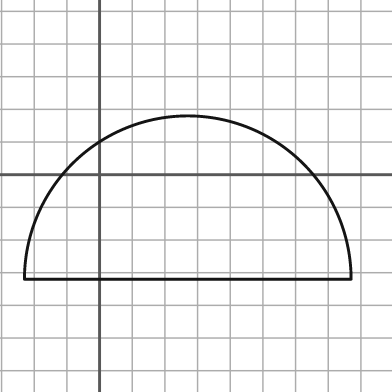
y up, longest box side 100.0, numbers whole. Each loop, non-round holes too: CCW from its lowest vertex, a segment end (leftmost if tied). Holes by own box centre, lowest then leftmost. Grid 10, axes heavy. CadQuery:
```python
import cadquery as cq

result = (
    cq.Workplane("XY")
    .moveTo(-23.0, -32.0)
    .lineTo(77.0, -32.0)
    .threePointArc((27.0, 18.0), (-23.0, -32.0))
    .close()
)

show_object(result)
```